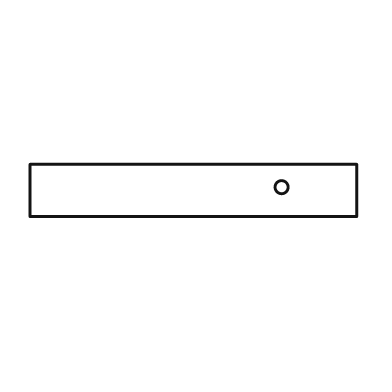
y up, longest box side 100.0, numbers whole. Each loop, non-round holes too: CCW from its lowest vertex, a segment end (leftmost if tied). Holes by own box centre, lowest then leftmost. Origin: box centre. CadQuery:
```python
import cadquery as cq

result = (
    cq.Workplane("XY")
    .moveTo(-50.0, -8.0)
    .lineTo(50.0, -8.0)
    .lineTo(50.0, 8.0)
    .lineTo(-50.0, 8.0)
    .close()
    .moveTo(27.0, 1.0)
    .circle(2.0)
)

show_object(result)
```